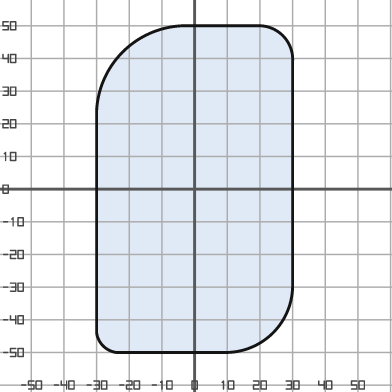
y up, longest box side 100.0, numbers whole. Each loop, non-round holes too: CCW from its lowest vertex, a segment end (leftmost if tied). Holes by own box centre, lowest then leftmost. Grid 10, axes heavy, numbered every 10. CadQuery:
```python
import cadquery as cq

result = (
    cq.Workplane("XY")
    .moveTo(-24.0, -50.0)
    .lineTo(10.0, -50.0)
    .threePointArc((24.0, -44.0), (30.0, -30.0))
    .lineTo(30.0, 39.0)
    .threePointArc((27.0, 47.0), (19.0, 50.0))
    .lineTo(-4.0, 50.0)
    .threePointArc((-22.0, 42.0), (-30.0, 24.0))
    .lineTo(-30.0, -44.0)
    .threePointArc((-28.0, -48.0), (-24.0, -50.0))
    .close()
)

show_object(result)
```